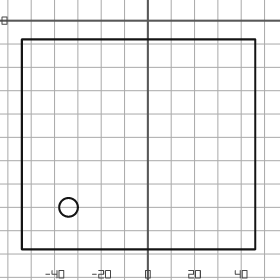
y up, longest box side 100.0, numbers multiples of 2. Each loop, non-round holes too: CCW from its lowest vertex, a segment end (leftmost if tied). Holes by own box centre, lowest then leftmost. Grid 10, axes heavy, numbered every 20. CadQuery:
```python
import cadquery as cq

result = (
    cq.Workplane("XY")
    .moveTo(-54.0, -98.0)
    .lineTo(46.0, -98.0)
    .lineTo(46.0, -8.0)
    .lineTo(-54.0, -8.0)
    .close()
    .moveTo(-34.0, -80.0)
    .circle(4.0)
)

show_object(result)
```